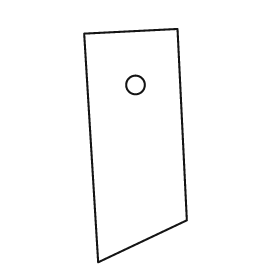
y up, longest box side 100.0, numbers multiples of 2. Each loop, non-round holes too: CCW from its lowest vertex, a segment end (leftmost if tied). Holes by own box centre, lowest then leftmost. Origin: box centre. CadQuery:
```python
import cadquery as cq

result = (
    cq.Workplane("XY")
    .moveTo(-16.0, -50.0)
    .lineTo(22.0, -32.0)
    .lineTo(18.0, 50.0)
    .lineTo(-22.0, 48.0)
    .close()
    .moveTo(0.0, 26.0)
    .circle(4.0)
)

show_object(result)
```